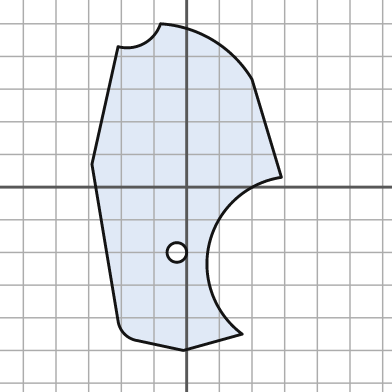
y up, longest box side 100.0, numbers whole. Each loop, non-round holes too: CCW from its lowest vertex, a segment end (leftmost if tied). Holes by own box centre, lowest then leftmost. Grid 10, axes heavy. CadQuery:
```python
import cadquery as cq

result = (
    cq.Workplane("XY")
    .moveTo(-1.0, -50.0)
    .lineTo(17.0, -45.0)
    .threePointArc((7.0, -17.0), (29.0, 3.0))
    .lineTo(20.0, 33.0)
    .threePointArc((8.0, 45.0), (-8.0, 50.0))
    .threePointArc((-13.0, 44.0), (-21.0, 43.0))
    .lineTo(-29.0, 7.0)
    .lineTo(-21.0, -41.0)
    .threePointArc((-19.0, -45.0), (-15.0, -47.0))
    .close()
    .moveTo(-3.0, -20.0)
    .circle(3.0)
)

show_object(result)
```